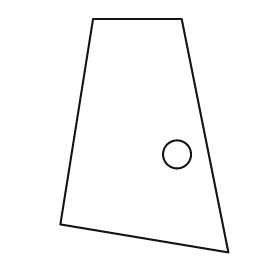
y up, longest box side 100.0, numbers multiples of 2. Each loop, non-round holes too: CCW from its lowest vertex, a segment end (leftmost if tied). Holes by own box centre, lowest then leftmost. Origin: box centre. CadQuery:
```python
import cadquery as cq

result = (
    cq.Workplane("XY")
    .moveTo(36.0, -50.0)
    .lineTo(16.0, 50.0)
    .lineTo(-22.0, 50.0)
    .lineTo(-36.0, -38.0)
    .close()
    .moveTo(14.0, -8.0)
    .circle(6.0)
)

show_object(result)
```